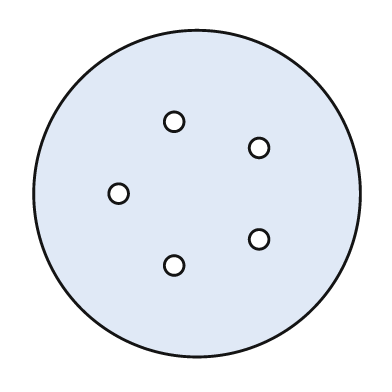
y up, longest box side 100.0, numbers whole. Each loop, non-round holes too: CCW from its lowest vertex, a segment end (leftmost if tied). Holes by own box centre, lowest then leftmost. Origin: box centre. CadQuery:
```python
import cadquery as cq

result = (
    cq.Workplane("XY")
    .moveTo(0.0, 0.0)
    .circle(50.0)
    .moveTo(-7.0, -22.0)
    .circle(3.0)
    .moveTo(19.0, -14.0)
    .circle(3.0)
    .moveTo(-24.0, 0.0)
    .circle(3.0)
    .moveTo(19.0, 14.0)
    .circle(3.0)
    .moveTo(-7.0, 22.0)
    .circle(3.0)
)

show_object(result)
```